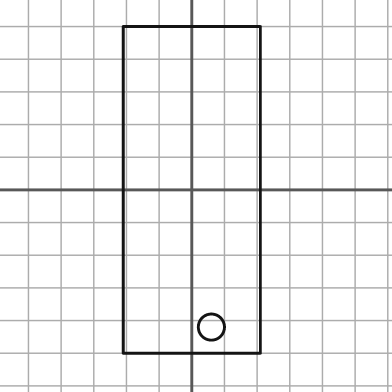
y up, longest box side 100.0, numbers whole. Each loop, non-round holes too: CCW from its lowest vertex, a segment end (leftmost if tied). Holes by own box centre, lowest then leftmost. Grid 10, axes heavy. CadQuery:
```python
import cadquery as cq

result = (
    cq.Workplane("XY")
    .moveTo(-21.0, -50.0)
    .lineTo(21.0, -50.0)
    .lineTo(21.0, 50.0)
    .lineTo(-21.0, 50.0)
    .close()
    .moveTo(6.0, -42.0)
    .circle(4.0)
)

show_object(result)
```